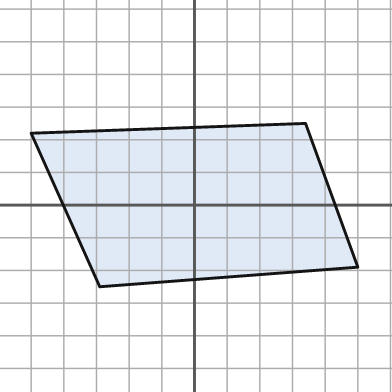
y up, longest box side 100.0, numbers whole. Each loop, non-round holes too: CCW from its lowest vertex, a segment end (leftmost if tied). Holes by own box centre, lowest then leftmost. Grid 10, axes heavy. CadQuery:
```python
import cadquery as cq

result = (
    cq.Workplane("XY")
    .moveTo(-29.0, -25.0)
    .lineTo(50.0, -19.0)
    .lineTo(34.0, 25.0)
    .lineTo(-50.0, 22.0)
    .close()
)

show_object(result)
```